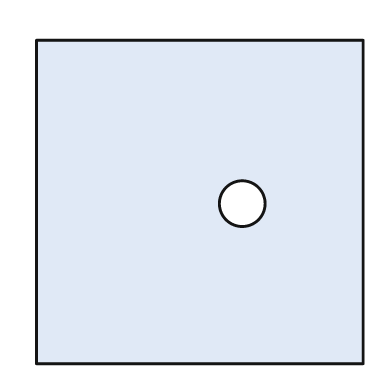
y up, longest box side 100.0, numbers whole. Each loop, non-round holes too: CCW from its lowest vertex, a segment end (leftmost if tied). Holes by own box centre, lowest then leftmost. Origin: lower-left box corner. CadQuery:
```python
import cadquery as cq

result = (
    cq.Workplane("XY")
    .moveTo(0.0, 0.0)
    .lineTo(100.0, 0.0)
    .lineTo(100.0, 99.0)
    .lineTo(0.0, 99.0)
    .close()
    .moveTo(63.0, 49.0)
    .circle(7.0)
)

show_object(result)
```